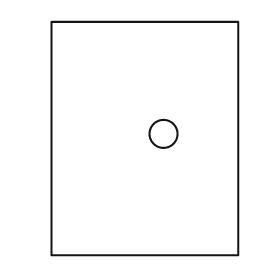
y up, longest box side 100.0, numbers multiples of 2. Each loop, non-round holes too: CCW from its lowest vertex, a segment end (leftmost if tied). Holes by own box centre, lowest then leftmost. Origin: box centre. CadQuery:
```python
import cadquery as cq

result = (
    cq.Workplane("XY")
    .moveTo(-40.0, -50.0)
    .lineTo(40.0, -50.0)
    .lineTo(40.0, 50.0)
    .lineTo(-40.0, 50.0)
    .close()
    .moveTo(8.0, 2.0)
    .circle(6.0)
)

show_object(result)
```